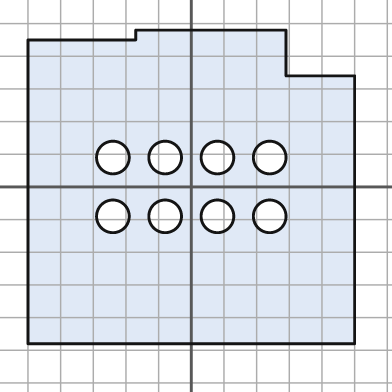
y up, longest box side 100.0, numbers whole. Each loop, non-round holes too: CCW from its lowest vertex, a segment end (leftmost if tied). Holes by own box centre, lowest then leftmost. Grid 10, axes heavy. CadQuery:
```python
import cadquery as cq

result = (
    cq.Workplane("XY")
    .moveTo(-50.0, -48.0)
    .lineTo(50.0, -48.0)
    .lineTo(50.0, 34.0)
    .lineTo(29.0, 34.0)
    .lineTo(29.0, 48.0)
    .lineTo(-17.0, 48.0)
    .lineTo(-17.0, 45.0)
    .lineTo(-50.0, 45.0)
    .close()
    .moveTo(-24.0, -9.0)
    .circle(5.0)
    .moveTo(-8.0, -9.0)
    .circle(5.0)
    .moveTo(8.0, -9.0)
    .circle(5.0)
    .moveTo(24.0, -9.0)
    .circle(5.0)
    .moveTo(-24.0, 9.0)
    .circle(5.0)
    .moveTo(-8.0, 9.0)
    .circle(5.0)
    .moveTo(8.0, 9.0)
    .circle(5.0)
    .moveTo(24.0, 9.0)
    .circle(5.0)
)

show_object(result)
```